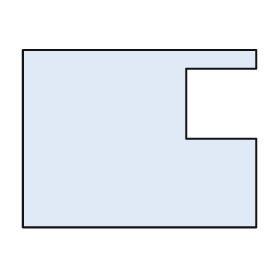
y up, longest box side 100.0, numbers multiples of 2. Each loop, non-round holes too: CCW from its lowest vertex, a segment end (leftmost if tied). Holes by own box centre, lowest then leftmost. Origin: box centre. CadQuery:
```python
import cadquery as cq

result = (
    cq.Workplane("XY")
    .moveTo(-50.0, -38.0)
    .lineTo(50.0, -38.0)
    .lineTo(50.0, 0.0)
    .lineTo(20.0, 0.0)
    .lineTo(20.0, 30.0)
    .lineTo(50.0, 30.0)
    .lineTo(50.0, 38.0)
    .lineTo(-50.0, 38.0)
    .close()
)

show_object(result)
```